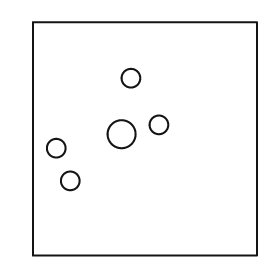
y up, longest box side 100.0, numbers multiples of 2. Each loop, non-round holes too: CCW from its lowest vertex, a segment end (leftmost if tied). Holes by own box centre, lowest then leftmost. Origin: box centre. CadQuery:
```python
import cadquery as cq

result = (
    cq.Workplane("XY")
    .moveTo(-48.0, -50.0)
    .lineTo(48.0, -50.0)
    .lineTo(48.0, 50.0)
    .lineTo(-48.0, 50.0)
    .close()
    .moveTo(-32.0, -18.0)
    .circle(4.0)
    .moveTo(-38.0, -4.0)
    .circle(4.0)
    .moveTo(-10.0, 2.0)
    .circle(6.0)
    .moveTo(6.0, 6.0)
    .circle(4.0)
    .moveTo(-6.0, 26.0)
    .circle(4.0)
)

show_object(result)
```